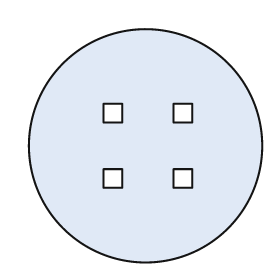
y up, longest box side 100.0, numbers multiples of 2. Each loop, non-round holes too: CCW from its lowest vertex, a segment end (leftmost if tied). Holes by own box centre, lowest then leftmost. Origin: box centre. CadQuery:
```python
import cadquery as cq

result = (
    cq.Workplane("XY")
    .moveTo(0.0, 0.0)
    .circle(50.0)
    .moveTo(-18.0, -18.0)
    .lineTo(-10.0, -18.0)
    .lineTo(-10.0, -10.0)
    .lineTo(-18.0, -10.0)
    .close()
    .moveTo(12.0, -18.0)
    .lineTo(20.0, -18.0)
    .lineTo(20.0, -10.0)
    .lineTo(12.0, -10.0)
    .close()
    .moveTo(-18.0, 10.0)
    .lineTo(-10.0, 10.0)
    .lineTo(-10.0, 18.0)
    .lineTo(-18.0, 18.0)
    .close()
    .moveTo(12.0, 10.0)
    .lineTo(20.0, 10.0)
    .lineTo(20.0, 18.0)
    .lineTo(12.0, 18.0)
    .close()
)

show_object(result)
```